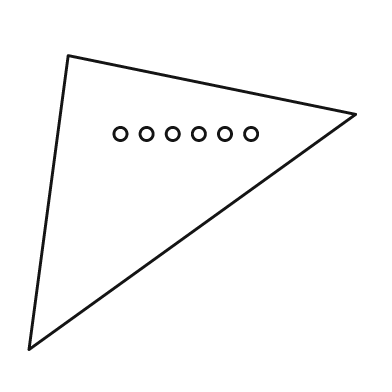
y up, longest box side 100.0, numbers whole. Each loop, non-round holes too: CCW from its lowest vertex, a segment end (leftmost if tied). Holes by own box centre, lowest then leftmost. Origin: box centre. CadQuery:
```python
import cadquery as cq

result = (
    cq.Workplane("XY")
    .moveTo(-50.0, -45.0)
    .lineTo(50.0, 27.0)
    .lineTo(-38.0, 45.0)
    .close()
    .moveTo(-22.0, 21.0)
    .circle(2.0)
    .moveTo(-14.0, 21.0)
    .circle(2.0)
    .moveTo(-6.0, 21.0)
    .circle(2.0)
    .moveTo(2.0, 21.0)
    .circle(2.0)
    .moveTo(10.0, 21.0)
    .circle(2.0)
    .moveTo(18.0, 21.0)
    .circle(2.0)
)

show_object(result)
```